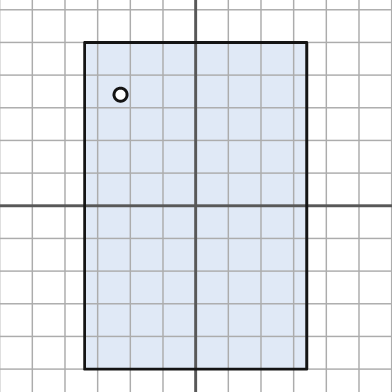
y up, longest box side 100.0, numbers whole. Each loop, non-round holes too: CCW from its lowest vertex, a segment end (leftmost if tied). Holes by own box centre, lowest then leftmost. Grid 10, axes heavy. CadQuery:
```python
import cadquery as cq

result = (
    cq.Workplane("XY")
    .moveTo(-34.0, -50.0)
    .lineTo(34.0, -50.0)
    .lineTo(34.0, 50.0)
    .lineTo(-34.0, 50.0)
    .close()
    .moveTo(-23.0, 34.0)
    .circle(2.0)
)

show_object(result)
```